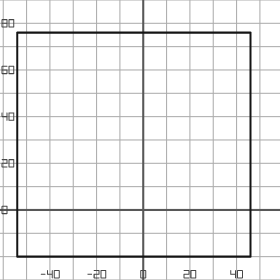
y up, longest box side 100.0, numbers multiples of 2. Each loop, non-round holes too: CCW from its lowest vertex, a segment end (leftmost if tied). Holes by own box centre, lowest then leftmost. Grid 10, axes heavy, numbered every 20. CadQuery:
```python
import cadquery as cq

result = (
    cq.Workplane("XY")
    .moveTo(-54.0, -20.0)
    .lineTo(46.0, -20.0)
    .lineTo(46.0, 76.0)
    .lineTo(-54.0, 76.0)
    .close()
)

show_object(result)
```